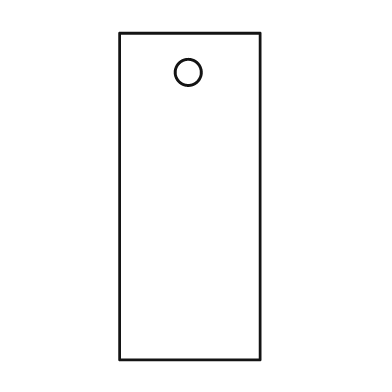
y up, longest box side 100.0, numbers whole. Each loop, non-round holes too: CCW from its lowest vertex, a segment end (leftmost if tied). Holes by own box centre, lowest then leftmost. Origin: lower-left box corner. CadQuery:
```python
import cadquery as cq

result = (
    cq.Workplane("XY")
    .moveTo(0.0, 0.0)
    .lineTo(43.0, 0.0)
    .lineTo(43.0, 100.0)
    .lineTo(0.0, 100.0)
    .close()
    .moveTo(21.0, 88.0)
    .circle(4.0)
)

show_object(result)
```